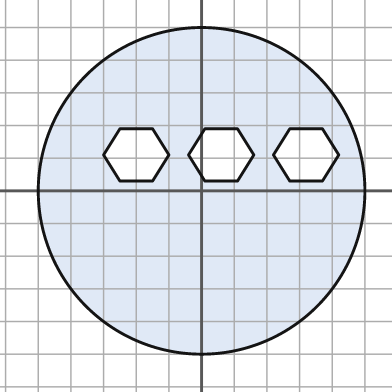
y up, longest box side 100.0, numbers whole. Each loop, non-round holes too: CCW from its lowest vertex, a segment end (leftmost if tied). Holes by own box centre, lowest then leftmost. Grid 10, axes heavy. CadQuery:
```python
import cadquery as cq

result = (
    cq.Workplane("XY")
    .moveTo(0.0, 0.0)
    .circle(50.0)
    .moveTo(-25.0, 3.0)
    .lineTo(-15.0, 3.0)
    .lineTo(-10.0, 11.0)
    .lineTo(-15.0, 19.0)
    .lineTo(-25.0, 19.0)
    .lineTo(-30.0, 11.0)
    .close()
    .moveTo(1.0, 3.0)
    .lineTo(11.0, 3.0)
    .lineTo(16.0, 11.0)
    .lineTo(11.0, 19.0)
    .lineTo(1.0, 19.0)
    .lineTo(-4.0, 11.0)
    .close()
    .moveTo(27.0, 3.0)
    .lineTo(37.0, 3.0)
    .lineTo(42.0, 11.0)
    .lineTo(37.0, 19.0)
    .lineTo(27.0, 19.0)
    .lineTo(22.0, 11.0)
    .close()
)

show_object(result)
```